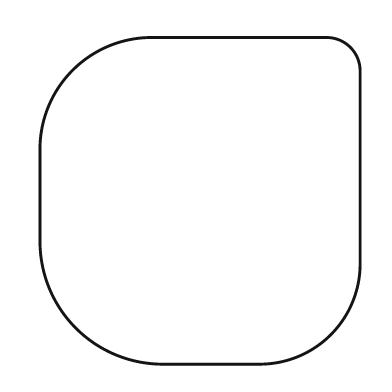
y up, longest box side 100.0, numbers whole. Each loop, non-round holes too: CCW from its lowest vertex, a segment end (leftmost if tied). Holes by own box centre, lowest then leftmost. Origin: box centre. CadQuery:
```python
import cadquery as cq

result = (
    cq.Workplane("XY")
    .moveTo(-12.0, -50.0)
    .lineTo(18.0, -50.0)
    .threePointArc((40.0, -41.0), (49.0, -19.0))
    .lineTo(49.0, 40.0)
    .threePointArc((46.0, 47.0), (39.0, 50.0))
    .lineTo(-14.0, 50.0)
    .threePointArc((-39.0, 40.0), (-49.0, 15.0))
    .lineTo(-49.0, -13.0)
    .threePointArc((-38.0, -39.0), (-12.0, -50.0))
    .close()
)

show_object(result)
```